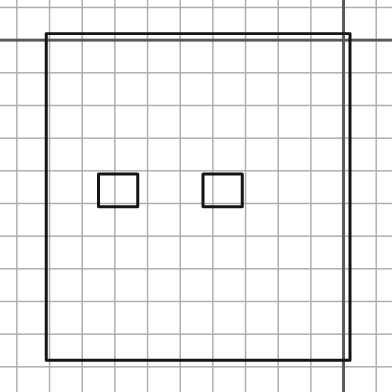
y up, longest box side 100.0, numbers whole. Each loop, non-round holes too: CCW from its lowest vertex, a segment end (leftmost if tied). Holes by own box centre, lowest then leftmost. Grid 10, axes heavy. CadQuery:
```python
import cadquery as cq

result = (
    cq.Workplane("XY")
    .moveTo(-91.0, -98.0)
    .lineTo(2.0, -98.0)
    .lineTo(2.0, 2.0)
    .lineTo(-91.0, 2.0)
    .close()
    .moveTo(-75.0, -51.0)
    .lineTo(-63.0, -51.0)
    .lineTo(-63.0, -41.0)
    .lineTo(-75.0, -41.0)
    .close()
    .moveTo(-43.0, -51.0)
    .lineTo(-31.0, -51.0)
    .lineTo(-31.0, -41.0)
    .lineTo(-43.0, -41.0)
    .close()
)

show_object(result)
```